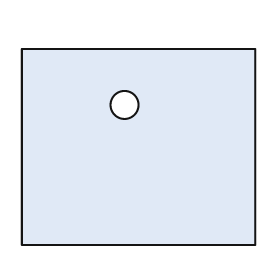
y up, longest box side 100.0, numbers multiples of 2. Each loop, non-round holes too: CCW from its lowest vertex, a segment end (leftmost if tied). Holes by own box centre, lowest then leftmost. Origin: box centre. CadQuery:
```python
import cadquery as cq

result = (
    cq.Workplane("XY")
    .moveTo(-50.0, -42.0)
    .lineTo(50.0, -42.0)
    .lineTo(50.0, 42.0)
    .lineTo(-50.0, 42.0)
    .close()
    .moveTo(-6.0, 18.0)
    .circle(6.0)
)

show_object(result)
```